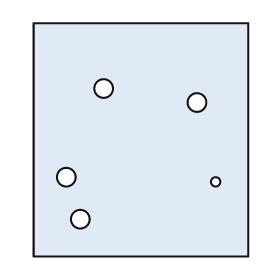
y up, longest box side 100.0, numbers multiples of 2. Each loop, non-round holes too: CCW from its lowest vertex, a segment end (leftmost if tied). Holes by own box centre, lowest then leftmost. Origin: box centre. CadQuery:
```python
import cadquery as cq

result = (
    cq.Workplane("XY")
    .moveTo(-46.0, -50.0)
    .lineTo(46.0, -50.0)
    .lineTo(46.0, 50.0)
    .lineTo(-46.0, 50.0)
    .close()
    .moveTo(-26.0, -34.0)
    .circle(4.0)
    .moveTo(32.0, -18.0)
    .circle(2.0)
    .moveTo(-32.0, -16.0)
    .circle(4.0)
    .moveTo(24.0, 16.0)
    .circle(4.0)
    .moveTo(-16.0, 22.0)
    .circle(4.0)
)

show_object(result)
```